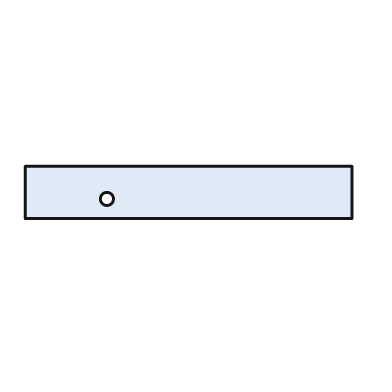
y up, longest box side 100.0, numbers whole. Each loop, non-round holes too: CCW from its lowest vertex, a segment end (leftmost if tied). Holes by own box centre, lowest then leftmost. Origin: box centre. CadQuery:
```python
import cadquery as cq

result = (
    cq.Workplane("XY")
    .moveTo(-50.0, -8.0)
    .lineTo(50.0, -8.0)
    .lineTo(50.0, 8.0)
    .lineTo(-50.0, 8.0)
    .close()
    .moveTo(-25.0, -2.0)
    .circle(2.0)
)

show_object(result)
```